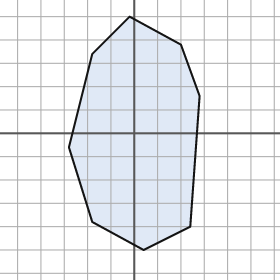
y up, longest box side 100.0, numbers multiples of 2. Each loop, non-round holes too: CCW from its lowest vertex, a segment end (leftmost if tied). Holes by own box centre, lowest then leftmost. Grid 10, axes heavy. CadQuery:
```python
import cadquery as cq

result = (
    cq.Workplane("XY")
    .moveTo(4.0, -50.0)
    .lineTo(24.0, -40.0)
    .lineTo(28.0, 16.0)
    .lineTo(20.0, 38.0)
    .lineTo(-2.0, 50.0)
    .lineTo(-18.0, 34.0)
    .lineTo(-28.0, -6.0)
    .lineTo(-18.0, -38.0)
    .close()
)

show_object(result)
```